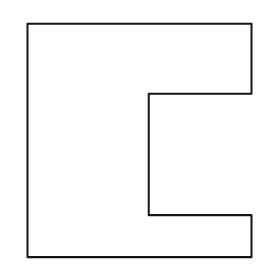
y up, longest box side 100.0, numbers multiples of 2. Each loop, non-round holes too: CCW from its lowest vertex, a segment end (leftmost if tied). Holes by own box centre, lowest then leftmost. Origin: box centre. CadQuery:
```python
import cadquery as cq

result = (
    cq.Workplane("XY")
    .moveTo(-48.0, -50.0)
    .lineTo(48.0, -50.0)
    .lineTo(48.0, -32.0)
    .lineTo(4.0, -32.0)
    .lineTo(4.0, 20.0)
    .lineTo(48.0, 20.0)
    .lineTo(48.0, 50.0)
    .lineTo(-48.0, 50.0)
    .close()
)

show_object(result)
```